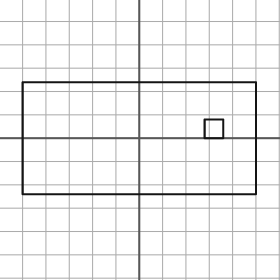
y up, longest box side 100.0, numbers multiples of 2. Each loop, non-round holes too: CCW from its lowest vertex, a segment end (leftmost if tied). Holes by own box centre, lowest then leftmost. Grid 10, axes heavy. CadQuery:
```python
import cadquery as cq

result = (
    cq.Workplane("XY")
    .moveTo(-50.0, -24.0)
    .lineTo(50.0, -24.0)
    .lineTo(50.0, 24.0)
    .lineTo(-50.0, 24.0)
    .close()
    .moveTo(28.0, 0.0)
    .lineTo(36.0, 0.0)
    .lineTo(36.0, 8.0)
    .lineTo(28.0, 8.0)
    .close()
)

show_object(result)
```